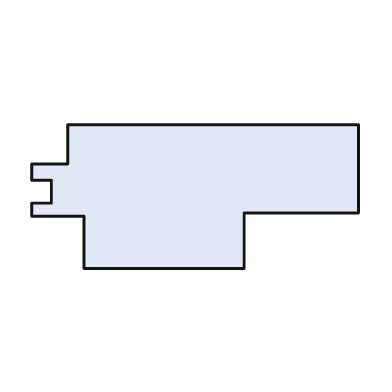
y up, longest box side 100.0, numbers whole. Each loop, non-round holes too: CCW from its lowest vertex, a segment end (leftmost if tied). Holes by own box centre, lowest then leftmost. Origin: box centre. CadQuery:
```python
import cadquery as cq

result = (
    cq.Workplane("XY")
    .moveTo(-34.0, -22.0)
    .lineTo(15.0, -22.0)
    .lineTo(15.0, -5.0)
    .lineTo(50.0, -5.0)
    .lineTo(50.0, 22.0)
    .lineTo(-39.0, 22.0)
    .lineTo(-39.0, 10.0)
    .lineTo(-50.0, 10.0)
    .lineTo(-50.0, 5.0)
    .lineTo(-44.0, 5.0)
    .lineTo(-44.0, -2.0)
    .lineTo(-50.0, -2.0)
    .lineTo(-50.0, -6.0)
    .lineTo(-34.0, -6.0)
    .close()
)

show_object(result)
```